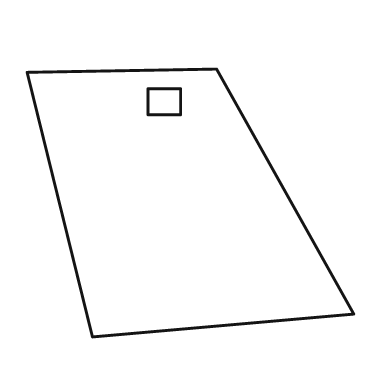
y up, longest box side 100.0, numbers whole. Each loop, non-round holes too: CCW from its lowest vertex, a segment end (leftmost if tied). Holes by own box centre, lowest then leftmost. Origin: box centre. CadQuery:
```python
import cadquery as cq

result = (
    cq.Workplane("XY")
    .moveTo(-30.0, -41.0)
    .lineTo(50.0, -34.0)
    .lineTo(8.0, 41.0)
    .lineTo(-50.0, 40.0)
    .close()
    .moveTo(-13.0, 27.0)
    .lineTo(-3.0, 27.0)
    .lineTo(-3.0, 35.0)
    .lineTo(-13.0, 35.0)
    .close()
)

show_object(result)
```